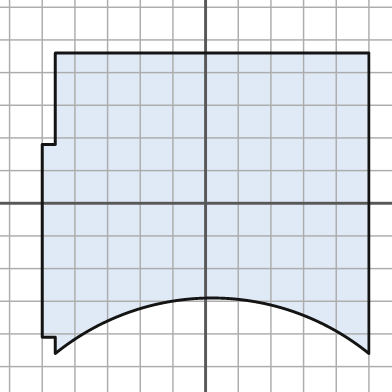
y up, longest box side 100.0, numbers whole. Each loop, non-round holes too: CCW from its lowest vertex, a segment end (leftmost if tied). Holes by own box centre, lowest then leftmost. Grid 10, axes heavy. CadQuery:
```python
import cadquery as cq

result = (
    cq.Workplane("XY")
    .moveTo(-46.0, -46.0)
    .threePointArc((2.0, -29.0), (50.0, -46.0))
    .lineTo(50.0, 46.0)
    .lineTo(-46.0, 46.0)
    .lineTo(-46.0, 18.0)
    .lineTo(-50.0, 18.0)
    .lineTo(-50.0, -41.0)
    .lineTo(-46.0, -41.0)
    .close()
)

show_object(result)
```